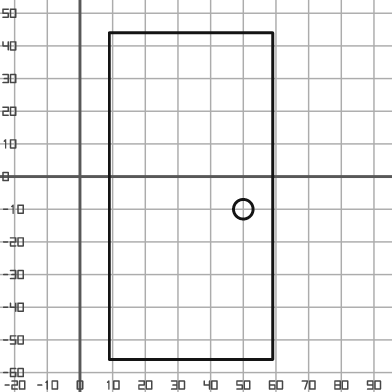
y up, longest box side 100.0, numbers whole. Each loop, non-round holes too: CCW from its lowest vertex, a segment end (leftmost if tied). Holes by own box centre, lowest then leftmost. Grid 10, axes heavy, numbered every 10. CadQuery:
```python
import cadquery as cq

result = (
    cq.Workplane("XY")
    .moveTo(9.0, -56.0)
    .lineTo(59.0, -56.0)
    .lineTo(59.0, 44.0)
    .lineTo(9.0, 44.0)
    .close()
    .moveTo(50.0, -10.0)
    .circle(3.0)
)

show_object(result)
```